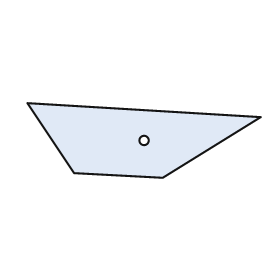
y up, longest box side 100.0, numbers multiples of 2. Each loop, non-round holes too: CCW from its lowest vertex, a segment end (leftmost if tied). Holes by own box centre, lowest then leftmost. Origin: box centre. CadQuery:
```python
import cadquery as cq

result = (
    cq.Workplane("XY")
    .moveTo(8.0, -16.0)
    .lineTo(50.0, 10.0)
    .lineTo(-50.0, 16.0)
    .lineTo(-30.0, -14.0)
    .close()
    .moveTo(0.0, 0.0)
    .circle(2.0)
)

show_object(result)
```